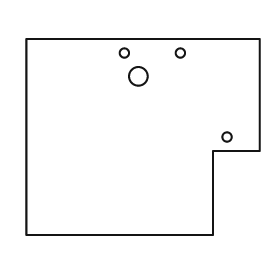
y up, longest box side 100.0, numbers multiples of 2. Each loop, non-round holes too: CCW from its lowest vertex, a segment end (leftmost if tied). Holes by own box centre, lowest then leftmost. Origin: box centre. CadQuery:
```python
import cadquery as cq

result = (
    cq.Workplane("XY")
    .moveTo(-50.0, -42.0)
    .lineTo(30.0, -42.0)
    .lineTo(30.0, -6.0)
    .lineTo(50.0, -6.0)
    .lineTo(50.0, 42.0)
    .lineTo(-50.0, 42.0)
    .close()
    .moveTo(36.0, 0.0)
    .circle(2.0)
    .moveTo(-2.0, 26.0)
    .circle(4.0)
    .moveTo(-8.0, 36.0)
    .circle(2.0)
    .moveTo(16.0, 36.0)
    .circle(2.0)
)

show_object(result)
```